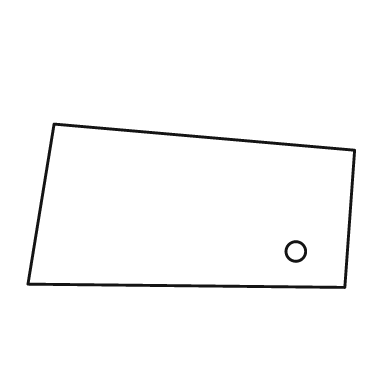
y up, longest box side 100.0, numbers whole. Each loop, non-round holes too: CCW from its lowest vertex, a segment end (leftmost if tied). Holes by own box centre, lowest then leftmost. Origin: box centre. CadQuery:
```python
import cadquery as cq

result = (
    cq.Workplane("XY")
    .moveTo(47.0, -25.0)
    .lineTo(50.0, 17.0)
    .lineTo(-42.0, 25.0)
    .lineTo(-50.0, -24.0)
    .close()
    .moveTo(32.0, -14.0)
    .circle(3.0)
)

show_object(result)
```